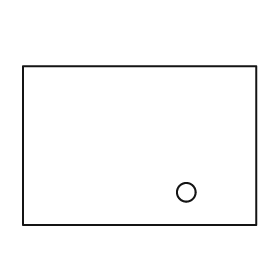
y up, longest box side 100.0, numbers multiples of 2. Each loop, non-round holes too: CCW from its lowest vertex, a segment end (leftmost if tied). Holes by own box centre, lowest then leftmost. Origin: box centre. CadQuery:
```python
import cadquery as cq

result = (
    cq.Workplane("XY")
    .moveTo(-50.0, -34.0)
    .lineTo(50.0, -34.0)
    .lineTo(50.0, 34.0)
    .lineTo(-50.0, 34.0)
    .close()
    .moveTo(20.0, -20.0)
    .circle(4.0)
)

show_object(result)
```